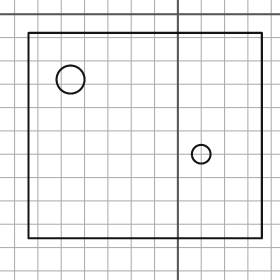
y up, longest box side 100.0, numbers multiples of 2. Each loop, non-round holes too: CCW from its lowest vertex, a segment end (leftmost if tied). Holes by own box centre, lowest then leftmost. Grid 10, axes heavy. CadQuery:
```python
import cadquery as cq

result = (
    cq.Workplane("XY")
    .moveTo(-64.0, -96.0)
    .lineTo(36.0, -96.0)
    .lineTo(36.0, -8.0)
    .lineTo(-64.0, -8.0)
    .close()
    .moveTo(10.0, -60.0)
    .circle(4.0)
    .moveTo(-46.0, -28.0)
    .circle(6.0)
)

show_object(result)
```